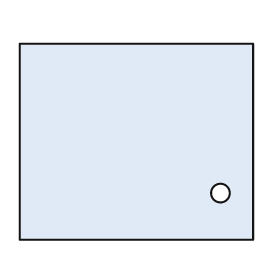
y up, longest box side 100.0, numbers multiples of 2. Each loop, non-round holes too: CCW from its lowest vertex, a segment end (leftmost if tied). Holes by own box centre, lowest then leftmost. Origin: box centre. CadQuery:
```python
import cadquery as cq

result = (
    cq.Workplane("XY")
    .moveTo(-50.0, -42.0)
    .lineTo(50.0, -42.0)
    .lineTo(50.0, 42.0)
    .lineTo(-50.0, 42.0)
    .close()
    .moveTo(36.0, -22.0)
    .circle(4.0)
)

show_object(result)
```